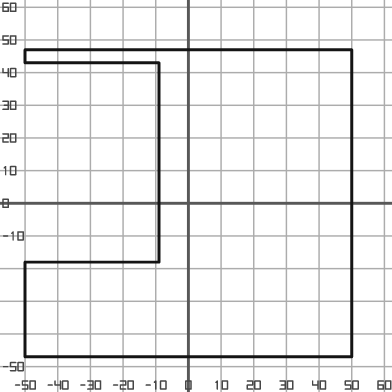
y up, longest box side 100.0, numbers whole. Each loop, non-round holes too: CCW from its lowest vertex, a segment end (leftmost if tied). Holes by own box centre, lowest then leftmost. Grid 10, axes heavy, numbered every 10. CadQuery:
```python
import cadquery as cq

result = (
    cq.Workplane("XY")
    .moveTo(-50.0, -47.0)
    .lineTo(50.0, -47.0)
    .lineTo(50.0, 47.0)
    .lineTo(-50.0, 47.0)
    .lineTo(-50.0, 43.0)
    .lineTo(-9.0, 43.0)
    .lineTo(-9.0, -18.0)
    .lineTo(-50.0, -18.0)
    .close()
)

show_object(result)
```